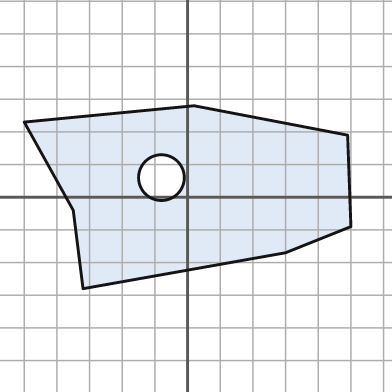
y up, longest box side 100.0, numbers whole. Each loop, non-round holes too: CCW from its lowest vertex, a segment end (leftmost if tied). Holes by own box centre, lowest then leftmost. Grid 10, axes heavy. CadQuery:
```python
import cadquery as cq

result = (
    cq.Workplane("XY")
    .moveTo(-32.0, -28.0)
    .lineTo(30.0, -17.0)
    .lineTo(50.0, -9.0)
    .lineTo(49.0, 19.0)
    .lineTo(2.0, 28.0)
    .lineTo(-50.0, 23.0)
    .lineTo(-35.0, -4.0)
    .close()
    .moveTo(-8.0, 6.0)
    .circle(7.0)
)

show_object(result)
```